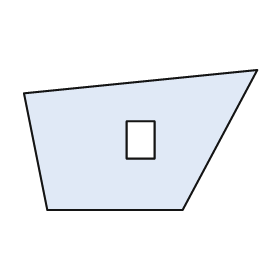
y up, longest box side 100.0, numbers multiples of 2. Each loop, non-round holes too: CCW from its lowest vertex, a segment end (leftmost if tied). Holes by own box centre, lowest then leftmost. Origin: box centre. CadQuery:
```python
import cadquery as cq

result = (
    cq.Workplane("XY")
    .moveTo(-40.0, -30.0)
    .lineTo(18.0, -30.0)
    .lineTo(50.0, 30.0)
    .lineTo(-50.0, 20.0)
    .close()
    .moveTo(-6.0, -8.0)
    .lineTo(6.0, -8.0)
    .lineTo(6.0, 8.0)
    .lineTo(-6.0, 8.0)
    .close()
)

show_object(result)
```